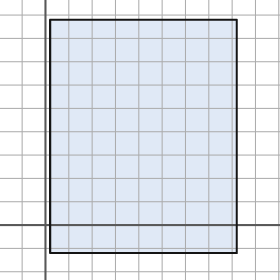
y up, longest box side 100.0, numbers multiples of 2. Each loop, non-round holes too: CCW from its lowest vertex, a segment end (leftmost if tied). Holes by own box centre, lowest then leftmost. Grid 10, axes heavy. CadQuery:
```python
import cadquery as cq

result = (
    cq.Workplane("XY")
    .moveTo(2.0, -12.0)
    .lineTo(82.0, -12.0)
    .lineTo(82.0, 88.0)
    .lineTo(2.0, 88.0)
    .close()
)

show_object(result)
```